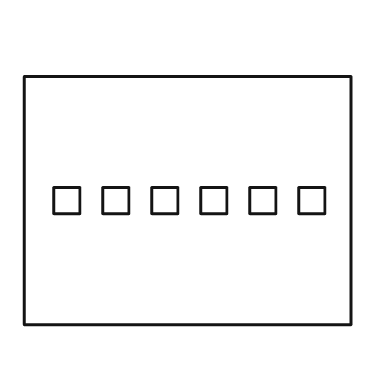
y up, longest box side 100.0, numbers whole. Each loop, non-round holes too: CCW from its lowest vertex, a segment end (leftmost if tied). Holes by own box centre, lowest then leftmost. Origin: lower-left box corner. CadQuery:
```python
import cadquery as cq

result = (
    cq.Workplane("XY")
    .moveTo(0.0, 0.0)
    .lineTo(100.0, 0.0)
    .lineTo(100.0, 76.0)
    .lineTo(0.0, 76.0)
    .close()
    .moveTo(9.0, 34.0)
    .lineTo(17.0, 34.0)
    .lineTo(17.0, 42.0)
    .lineTo(9.0, 42.0)
    .close()
    .moveTo(24.0, 34.0)
    .lineTo(32.0, 34.0)
    .lineTo(32.0, 42.0)
    .lineTo(24.0, 42.0)
    .close()
    .moveTo(39.0, 34.0)
    .lineTo(47.0, 34.0)
    .lineTo(47.0, 42.0)
    .lineTo(39.0, 42.0)
    .close()
    .moveTo(54.0, 34.0)
    .lineTo(62.0, 34.0)
    .lineTo(62.0, 42.0)
    .lineTo(54.0, 42.0)
    .close()
    .moveTo(69.0, 34.0)
    .lineTo(77.0, 34.0)
    .lineTo(77.0, 42.0)
    .lineTo(69.0, 42.0)
    .close()
    .moveTo(84.0, 34.0)
    .lineTo(92.0, 34.0)
    .lineTo(92.0, 42.0)
    .lineTo(84.0, 42.0)
    .close()
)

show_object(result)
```